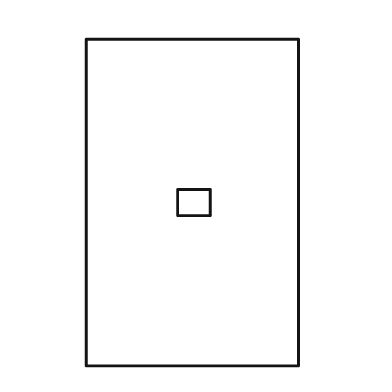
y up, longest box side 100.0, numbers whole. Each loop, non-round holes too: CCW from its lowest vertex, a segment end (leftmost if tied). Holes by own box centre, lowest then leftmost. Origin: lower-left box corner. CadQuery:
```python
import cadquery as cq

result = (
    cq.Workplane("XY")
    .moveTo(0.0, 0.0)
    .lineTo(65.0, 0.0)
    .lineTo(65.0, 100.0)
    .lineTo(0.0, 100.0)
    .close()
    .moveTo(28.0, 46.0)
    .lineTo(38.0, 46.0)
    .lineTo(38.0, 54.0)
    .lineTo(28.0, 54.0)
    .close()
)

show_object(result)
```